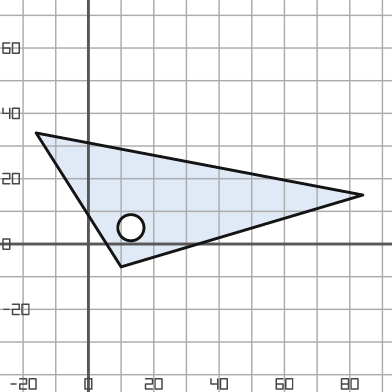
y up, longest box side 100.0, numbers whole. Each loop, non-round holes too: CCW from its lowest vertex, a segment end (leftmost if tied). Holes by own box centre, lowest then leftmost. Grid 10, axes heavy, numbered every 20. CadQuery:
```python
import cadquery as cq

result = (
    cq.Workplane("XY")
    .moveTo(10.0, -7.0)
    .lineTo(84.0, 15.0)
    .lineTo(-16.0, 34.0)
    .close()
    .moveTo(13.0, 5.0)
    .circle(4.0)
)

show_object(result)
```